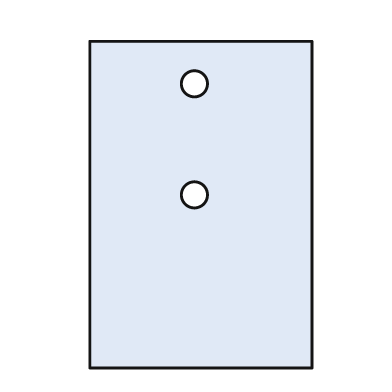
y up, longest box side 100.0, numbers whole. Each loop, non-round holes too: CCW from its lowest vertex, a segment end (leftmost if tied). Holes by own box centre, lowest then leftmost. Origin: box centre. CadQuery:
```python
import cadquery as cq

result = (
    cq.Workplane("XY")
    .moveTo(-34.0, -50.0)
    .lineTo(34.0, -50.0)
    .lineTo(34.0, 50.0)
    .lineTo(-34.0, 50.0)
    .close()
    .moveTo(-2.0, 3.0)
    .circle(4.0)
    .moveTo(-2.0, 37.0)
    .circle(4.0)
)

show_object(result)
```